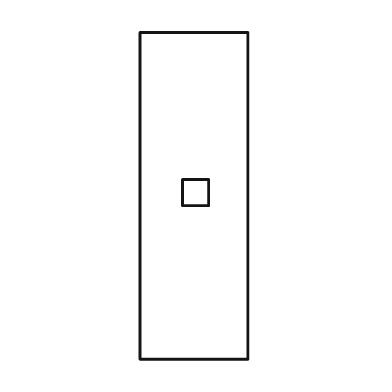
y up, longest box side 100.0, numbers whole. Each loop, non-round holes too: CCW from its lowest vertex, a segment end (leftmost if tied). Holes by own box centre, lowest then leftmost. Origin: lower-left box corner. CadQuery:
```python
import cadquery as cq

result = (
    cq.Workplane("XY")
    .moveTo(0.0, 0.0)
    .lineTo(33.0, 0.0)
    .lineTo(33.0, 100.0)
    .lineTo(0.0, 100.0)
    .close()
    .moveTo(13.0, 47.0)
    .lineTo(21.0, 47.0)
    .lineTo(21.0, 55.0)
    .lineTo(13.0, 55.0)
    .close()
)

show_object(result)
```